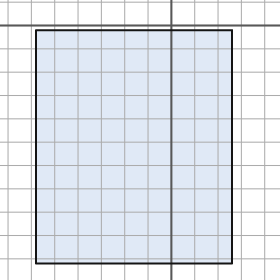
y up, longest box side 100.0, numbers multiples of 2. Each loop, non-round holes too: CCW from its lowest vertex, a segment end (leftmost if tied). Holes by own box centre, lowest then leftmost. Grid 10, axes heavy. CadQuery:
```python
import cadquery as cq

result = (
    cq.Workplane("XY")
    .moveTo(-58.0, -102.0)
    .lineTo(26.0, -102.0)
    .lineTo(26.0, -2.0)
    .lineTo(-58.0, -2.0)
    .close()
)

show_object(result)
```